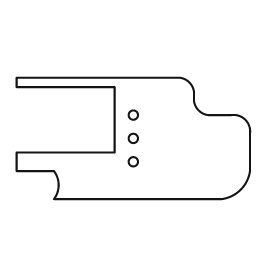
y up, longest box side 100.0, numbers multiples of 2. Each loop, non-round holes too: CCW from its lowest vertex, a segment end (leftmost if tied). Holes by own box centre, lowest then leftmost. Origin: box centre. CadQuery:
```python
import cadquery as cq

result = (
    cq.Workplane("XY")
    .moveTo(-34.0, -26.0)
    .lineTo(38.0, -26.0)
    .threePointArc((46.0, -22.0), (50.0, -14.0))
    .lineTo(50.0, 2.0)
    .threePointArc((48.0, 8.0), (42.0, 10.0))
    .lineTo(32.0, 10.0)
    .threePointArc((28.0, 12.0), (26.0, 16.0))
    .lineTo(26.0, 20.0)
    .threePointArc((24.0, 24.0), (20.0, 26.0))
    .lineTo(-50.0, 26.0)
    .lineTo(-50.0, 22.0)
    .lineTo(-8.0, 22.0)
    .lineTo(-8.0, -6.0)
    .lineTo(-50.0, -6.0)
    .lineTo(-50.0, -14.0)
    .lineTo(-34.0, -14.0)
    .threePointArc((-32.0, -20.0), (-34.0, -26.0))
    .close()
    .moveTo(0.0, -10.0)
    .circle(2.0)
    .moveTo(0.0, 0.0)
    .circle(2.0)
    .moveTo(0.0, 10.0)
    .circle(2.0)
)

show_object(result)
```